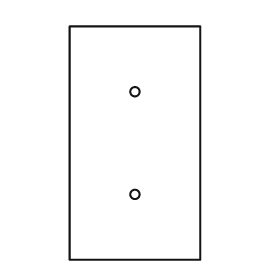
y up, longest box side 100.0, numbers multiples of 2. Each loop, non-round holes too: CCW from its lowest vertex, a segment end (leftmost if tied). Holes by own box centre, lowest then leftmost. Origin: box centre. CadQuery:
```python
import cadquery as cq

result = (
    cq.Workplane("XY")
    .moveTo(-28.0, -50.0)
    .lineTo(28.0, -50.0)
    .lineTo(28.0, 50.0)
    .lineTo(-28.0, 50.0)
    .close()
    .moveTo(0.0, -22.0)
    .circle(2.0)
    .moveTo(0.0, 22.0)
    .circle(2.0)
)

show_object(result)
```